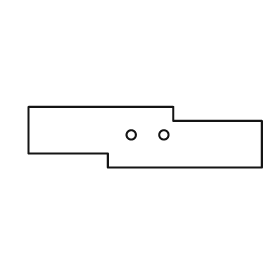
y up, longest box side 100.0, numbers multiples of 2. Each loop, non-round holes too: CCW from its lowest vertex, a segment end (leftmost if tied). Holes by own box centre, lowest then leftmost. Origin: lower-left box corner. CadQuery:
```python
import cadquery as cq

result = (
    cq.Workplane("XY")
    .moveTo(34.0, 0.0)
    .lineTo(100.0, 0.0)
    .lineTo(100.0, 20.0)
    .lineTo(62.0, 20.0)
    .lineTo(62.0, 26.0)
    .lineTo(0.0, 26.0)
    .lineTo(0.0, 6.0)
    .lineTo(34.0, 6.0)
    .close()
    .moveTo(44.0, 14.0)
    .circle(2.0)
    .moveTo(58.0, 14.0)
    .circle(2.0)
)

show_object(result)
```